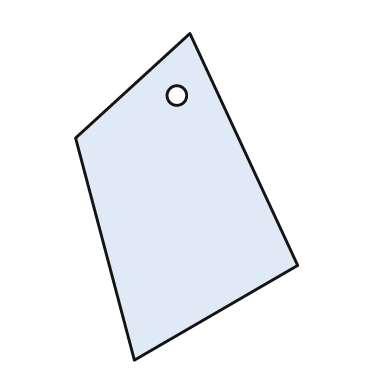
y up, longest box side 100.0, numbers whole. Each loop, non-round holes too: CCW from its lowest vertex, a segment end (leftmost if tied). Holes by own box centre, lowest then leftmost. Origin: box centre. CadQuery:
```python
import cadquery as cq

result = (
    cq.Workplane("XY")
    .moveTo(-16.0, -50.0)
    .lineTo(34.0, -21.0)
    .lineTo(1.0, 50.0)
    .lineTo(-34.0, 18.0)
    .close()
    .moveTo(-3.0, 31.0)
    .circle(3.0)
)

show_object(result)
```